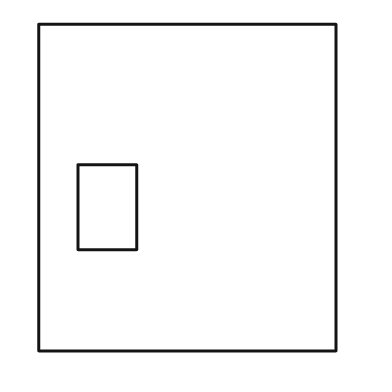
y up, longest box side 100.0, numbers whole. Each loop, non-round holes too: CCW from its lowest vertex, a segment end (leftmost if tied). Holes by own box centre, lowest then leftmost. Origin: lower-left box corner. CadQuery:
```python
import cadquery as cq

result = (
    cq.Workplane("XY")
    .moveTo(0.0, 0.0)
    .lineTo(91.0, 0.0)
    .lineTo(91.0, 100.0)
    .lineTo(0.0, 100.0)
    .close()
    .moveTo(12.0, 31.0)
    .lineTo(30.0, 31.0)
    .lineTo(30.0, 57.0)
    .lineTo(12.0, 57.0)
    .close()
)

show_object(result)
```